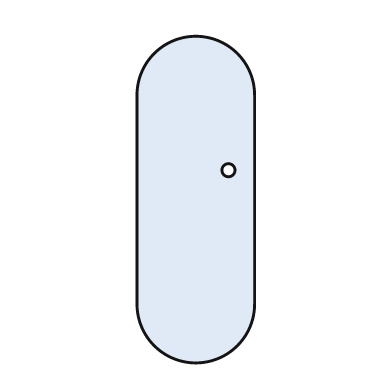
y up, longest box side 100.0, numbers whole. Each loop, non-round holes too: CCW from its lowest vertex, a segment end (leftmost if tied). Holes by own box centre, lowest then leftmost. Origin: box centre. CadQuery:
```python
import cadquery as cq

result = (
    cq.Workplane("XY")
    .moveTo(-18.0, -32.0)
    .threePointArc((0.0, -50.0), (18.0, -32.0))
    .lineTo(18.0, 32.0)
    .threePointArc((0.0, 50.0), (-18.0, 32.0))
    .close()
    .moveTo(10.0, 9.0)
    .circle(2.0)
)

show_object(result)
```